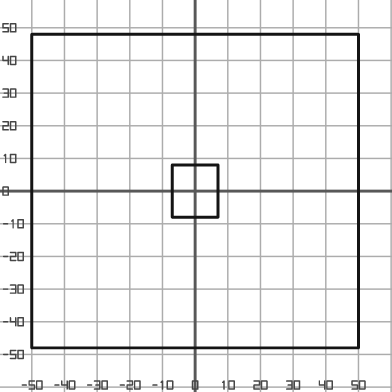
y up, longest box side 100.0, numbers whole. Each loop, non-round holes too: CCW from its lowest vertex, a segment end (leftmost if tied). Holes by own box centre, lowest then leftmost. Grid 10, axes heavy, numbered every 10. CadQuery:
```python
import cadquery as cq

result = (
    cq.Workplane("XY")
    .moveTo(-50.0, -48.0)
    .lineTo(50.0, -48.0)
    .lineTo(50.0, 48.0)
    .lineTo(-50.0, 48.0)
    .close()
    .moveTo(-7.0, -8.0)
    .lineTo(7.0, -8.0)
    .lineTo(7.0, 8.0)
    .lineTo(-7.0, 8.0)
    .close()
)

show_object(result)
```